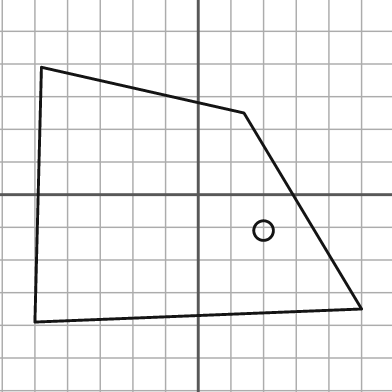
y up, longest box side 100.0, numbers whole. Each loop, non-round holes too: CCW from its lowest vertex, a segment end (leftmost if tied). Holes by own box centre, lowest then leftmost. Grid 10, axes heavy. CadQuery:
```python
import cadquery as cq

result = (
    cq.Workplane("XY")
    .moveTo(-50.0, -39.0)
    .lineTo(50.0, -35.0)
    .lineTo(14.0, 25.0)
    .lineTo(-48.0, 39.0)
    .close()
    .moveTo(20.0, -11.0)
    .circle(3.0)
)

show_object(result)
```